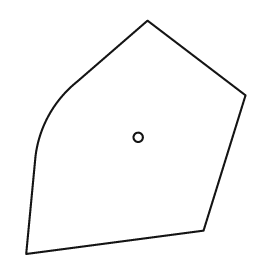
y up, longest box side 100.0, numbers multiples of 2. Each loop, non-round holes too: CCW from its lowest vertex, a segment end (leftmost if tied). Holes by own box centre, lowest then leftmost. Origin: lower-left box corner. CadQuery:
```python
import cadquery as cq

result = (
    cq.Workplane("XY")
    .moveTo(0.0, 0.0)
    .lineTo(76.0, 10.0)
    .lineTo(94.0, 68.0)
    .lineTo(52.0, 100.0)
    .lineTo(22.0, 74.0)
    .threePointArc((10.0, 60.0), (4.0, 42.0))
    .close()
    .moveTo(48.0, 50.0)
    .circle(2.0)
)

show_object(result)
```